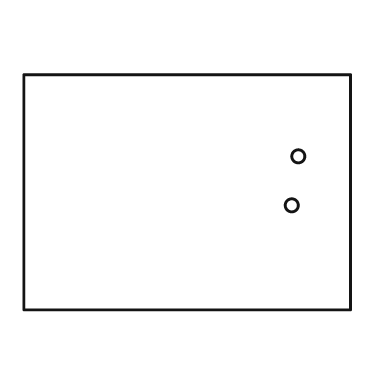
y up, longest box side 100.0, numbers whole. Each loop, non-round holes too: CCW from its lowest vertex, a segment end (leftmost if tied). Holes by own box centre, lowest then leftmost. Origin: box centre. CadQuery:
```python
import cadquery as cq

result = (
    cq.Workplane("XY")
    .moveTo(-50.0, -36.0)
    .lineTo(50.0, -36.0)
    .lineTo(50.0, 36.0)
    .lineTo(-50.0, 36.0)
    .close()
    .moveTo(32.0, -4.0)
    .circle(2.0)
    .moveTo(34.0, 11.0)
    .circle(2.0)
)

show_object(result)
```